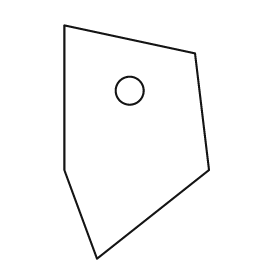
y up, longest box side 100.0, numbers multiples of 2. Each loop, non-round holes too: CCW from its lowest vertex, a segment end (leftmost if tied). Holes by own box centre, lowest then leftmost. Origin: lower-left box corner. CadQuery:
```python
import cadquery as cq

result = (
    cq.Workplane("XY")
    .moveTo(14.0, 0.0)
    .lineTo(62.0, 38.0)
    .lineTo(56.0, 88.0)
    .lineTo(0.0, 100.0)
    .lineTo(0.0, 38.0)
    .close()
    .moveTo(28.0, 72.0)
    .circle(6.0)
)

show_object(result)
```